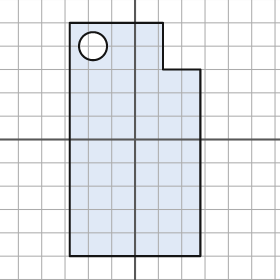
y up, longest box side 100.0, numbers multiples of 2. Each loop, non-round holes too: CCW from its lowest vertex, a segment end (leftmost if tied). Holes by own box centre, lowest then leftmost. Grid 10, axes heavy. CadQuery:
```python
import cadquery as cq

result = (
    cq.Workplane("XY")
    .moveTo(-28.0, -50.0)
    .lineTo(28.0, -50.0)
    .lineTo(28.0, 30.0)
    .lineTo(12.0, 30.0)
    .lineTo(12.0, 50.0)
    .lineTo(-28.0, 50.0)
    .close()
    .moveTo(-18.0, 40.0)
    .circle(6.0)
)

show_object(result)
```